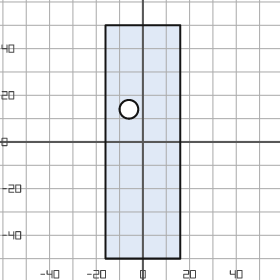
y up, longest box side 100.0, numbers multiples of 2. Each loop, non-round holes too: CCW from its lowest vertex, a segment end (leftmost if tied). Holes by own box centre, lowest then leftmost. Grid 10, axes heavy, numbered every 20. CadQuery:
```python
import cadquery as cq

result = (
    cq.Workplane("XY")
    .moveTo(-16.0, -50.0)
    .lineTo(16.0, -50.0)
    .lineTo(16.0, 50.0)
    .lineTo(-16.0, 50.0)
    .close()
    .moveTo(-6.0, 14.0)
    .circle(4.0)
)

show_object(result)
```